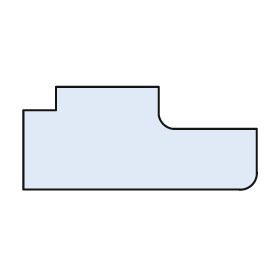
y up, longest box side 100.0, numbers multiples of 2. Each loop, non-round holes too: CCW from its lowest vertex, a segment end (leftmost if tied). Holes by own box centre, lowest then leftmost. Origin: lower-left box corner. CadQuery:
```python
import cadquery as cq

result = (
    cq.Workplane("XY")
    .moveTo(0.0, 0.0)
    .lineTo(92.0, 0.0)
    .threePointArc((98.0, 2.0), (100.0, 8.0))
    .lineTo(100.0, 26.0)
    .lineTo(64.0, 26.0)
    .threePointArc((60.0, 28.0), (58.0, 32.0))
    .lineTo(58.0, 44.0)
    .lineTo(14.0, 44.0)
    .lineTo(14.0, 34.0)
    .lineTo(0.0, 34.0)
    .close()
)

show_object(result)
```